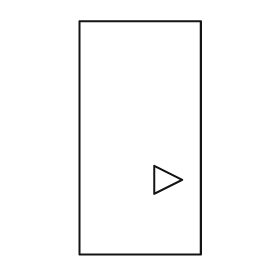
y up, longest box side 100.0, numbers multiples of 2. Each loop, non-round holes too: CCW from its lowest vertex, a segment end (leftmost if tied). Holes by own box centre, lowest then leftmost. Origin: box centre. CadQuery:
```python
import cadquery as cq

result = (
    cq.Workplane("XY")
    .moveTo(-26.0, -50.0)
    .lineTo(26.0, -50.0)
    .lineTo(26.0, 50.0)
    .lineTo(-26.0, 50.0)
    .close()
    .moveTo(6.0, -24.0)
    .lineTo(18.0, -18.0)
    .lineTo(6.0, -12.0)
    .close()
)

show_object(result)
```